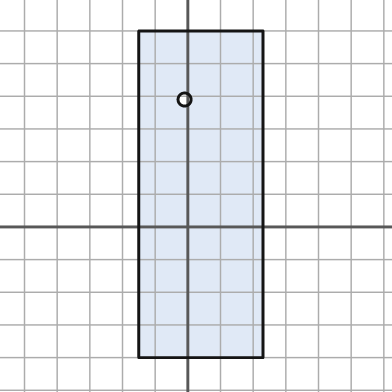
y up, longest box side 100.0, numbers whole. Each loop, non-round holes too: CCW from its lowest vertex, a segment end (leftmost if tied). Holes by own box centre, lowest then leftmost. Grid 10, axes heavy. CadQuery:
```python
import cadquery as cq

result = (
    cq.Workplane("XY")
    .moveTo(-15.0, -40.0)
    .lineTo(23.0, -40.0)
    .lineTo(23.0, 60.0)
    .lineTo(-15.0, 60.0)
    .close()
    .moveTo(-1.0, 39.0)
    .circle(2.0)
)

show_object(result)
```